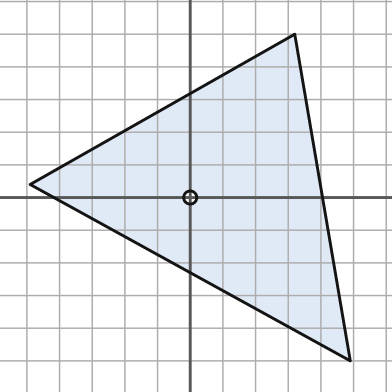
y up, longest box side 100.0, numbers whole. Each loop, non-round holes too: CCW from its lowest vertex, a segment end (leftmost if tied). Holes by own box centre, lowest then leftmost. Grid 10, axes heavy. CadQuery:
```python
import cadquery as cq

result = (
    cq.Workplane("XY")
    .moveTo(49.0, -50.0)
    .lineTo(32.0, 50.0)
    .lineTo(-49.0, 4.0)
    .close()
    .moveTo(0.0, 0.0)
    .circle(2.0)
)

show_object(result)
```